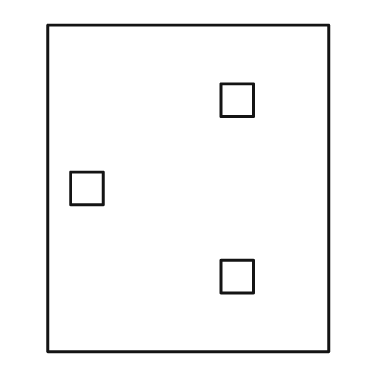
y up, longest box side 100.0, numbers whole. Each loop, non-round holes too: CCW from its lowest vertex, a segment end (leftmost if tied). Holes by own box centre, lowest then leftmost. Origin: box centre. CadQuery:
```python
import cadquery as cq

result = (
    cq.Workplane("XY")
    .moveTo(-43.0, -50.0)
    .lineTo(43.0, -50.0)
    .lineTo(43.0, 50.0)
    .lineTo(-43.0, 50.0)
    .close()
    .moveTo(10.0, -32.0)
    .lineTo(20.0, -32.0)
    .lineTo(20.0, -22.0)
    .lineTo(10.0, -22.0)
    .close()
    .moveTo(-36.0, -5.0)
    .lineTo(-26.0, -5.0)
    .lineTo(-26.0, 5.0)
    .lineTo(-36.0, 5.0)
    .close()
    .moveTo(10.0, 22.0)
    .lineTo(20.0, 22.0)
    .lineTo(20.0, 32.0)
    .lineTo(10.0, 32.0)
    .close()
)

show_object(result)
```